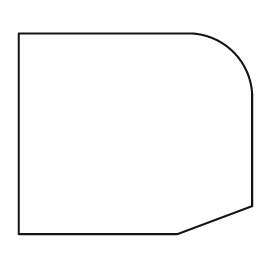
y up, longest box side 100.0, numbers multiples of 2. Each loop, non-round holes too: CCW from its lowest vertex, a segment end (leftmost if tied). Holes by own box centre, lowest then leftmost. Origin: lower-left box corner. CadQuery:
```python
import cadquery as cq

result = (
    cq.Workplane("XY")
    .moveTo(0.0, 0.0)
    .lineTo(68.0, 0.0)
    .lineTo(100.0, 12.0)
    .lineTo(100.0, 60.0)
    .threePointArc((92.0, 78.0), (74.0, 86.0))
    .lineTo(0.0, 86.0)
    .close()
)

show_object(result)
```